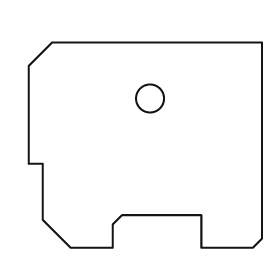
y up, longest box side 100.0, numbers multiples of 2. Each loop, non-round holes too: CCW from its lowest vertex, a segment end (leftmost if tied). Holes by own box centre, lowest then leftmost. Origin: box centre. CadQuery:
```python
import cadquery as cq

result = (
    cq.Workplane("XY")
    .moveTo(-32.0, -44.0)
    .lineTo(-14.0, -44.0)
    .lineTo(-14.0, -34.0)
    .lineTo(-10.0, -30.0)
    .lineTo(24.0, -30.0)
    .lineTo(24.0, -44.0)
    .lineTo(46.0, -44.0)
    .lineTo(50.0, -40.0)
    .lineTo(50.0, 44.0)
    .lineTo(-40.0, 44.0)
    .lineTo(-50.0, 34.0)
    .lineTo(-50.0, -8.0)
    .lineTo(-44.0, -8.0)
    .lineTo(-44.0, -32.0)
    .close()
    .moveTo(2.0, 20.0)
    .circle(6.0)
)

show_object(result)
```